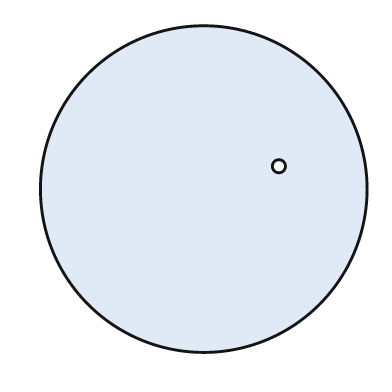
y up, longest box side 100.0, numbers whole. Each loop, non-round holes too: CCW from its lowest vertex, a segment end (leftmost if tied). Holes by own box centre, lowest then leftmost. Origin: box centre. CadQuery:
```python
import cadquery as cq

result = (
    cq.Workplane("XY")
    .moveTo(0.0, 0.0)
    .circle(50.0)
    .moveTo(23.0, 7.0)
    .circle(2.0)
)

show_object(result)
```